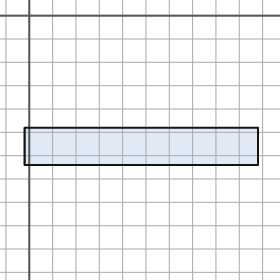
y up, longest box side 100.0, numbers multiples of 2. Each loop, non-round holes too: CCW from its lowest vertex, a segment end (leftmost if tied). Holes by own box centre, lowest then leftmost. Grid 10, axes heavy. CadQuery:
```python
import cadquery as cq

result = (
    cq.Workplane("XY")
    .moveTo(-2.0, -64.0)
    .lineTo(98.0, -64.0)
    .lineTo(98.0, -48.0)
    .lineTo(-2.0, -48.0)
    .close()
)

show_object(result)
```